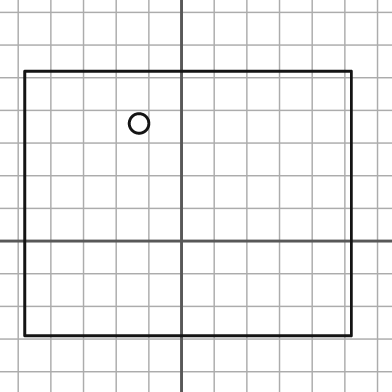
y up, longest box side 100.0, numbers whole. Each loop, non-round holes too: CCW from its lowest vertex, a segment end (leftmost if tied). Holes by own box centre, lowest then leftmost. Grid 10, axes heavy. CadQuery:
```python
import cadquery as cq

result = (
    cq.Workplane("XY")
    .moveTo(-48.0, -29.0)
    .lineTo(52.0, -29.0)
    .lineTo(52.0, 52.0)
    .lineTo(-48.0, 52.0)
    .close()
    .moveTo(-13.0, 36.0)
    .circle(3.0)
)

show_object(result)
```